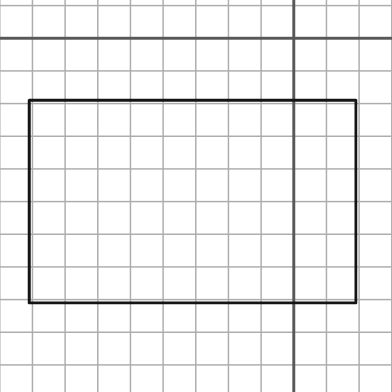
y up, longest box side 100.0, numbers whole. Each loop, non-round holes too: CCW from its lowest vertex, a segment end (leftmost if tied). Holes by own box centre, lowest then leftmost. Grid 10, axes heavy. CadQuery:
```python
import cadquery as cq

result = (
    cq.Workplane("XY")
    .moveTo(-81.0, -81.0)
    .lineTo(19.0, -81.0)
    .lineTo(19.0, -19.0)
    .lineTo(-81.0, -19.0)
    .close()
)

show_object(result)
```